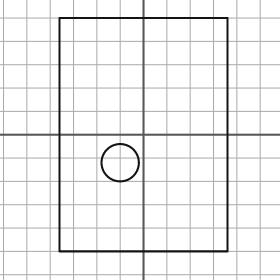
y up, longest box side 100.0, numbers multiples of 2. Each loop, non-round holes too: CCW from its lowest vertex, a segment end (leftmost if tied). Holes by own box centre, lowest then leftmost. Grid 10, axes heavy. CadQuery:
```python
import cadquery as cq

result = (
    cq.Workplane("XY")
    .moveTo(-36.0, -50.0)
    .lineTo(36.0, -50.0)
    .lineTo(36.0, 50.0)
    .lineTo(-36.0, 50.0)
    .close()
    .moveTo(-10.0, -12.0)
    .circle(8.0)
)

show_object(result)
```